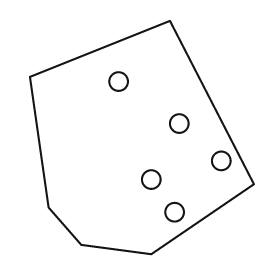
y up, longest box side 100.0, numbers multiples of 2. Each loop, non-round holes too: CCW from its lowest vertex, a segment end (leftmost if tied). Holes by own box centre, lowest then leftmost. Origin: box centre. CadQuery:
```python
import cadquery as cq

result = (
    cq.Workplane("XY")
    .moveTo(4.0, -50.0)
    .lineTo(48.0, -20.0)
    .lineTo(12.0, 50.0)
    .lineTo(-48.0, 26.0)
    .lineTo(-40.0, -30.0)
    .lineTo(-26.0, -46.0)
    .close()
    .moveTo(14.0, -32.0)
    .circle(4.0)
    .moveTo(4.0, -18.0)
    .circle(4.0)
    .moveTo(34.0, -10.0)
    .circle(4.0)
    .moveTo(16.0, 6.0)
    .circle(4.0)
    .moveTo(-10.0, 24.0)
    .circle(4.0)
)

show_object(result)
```